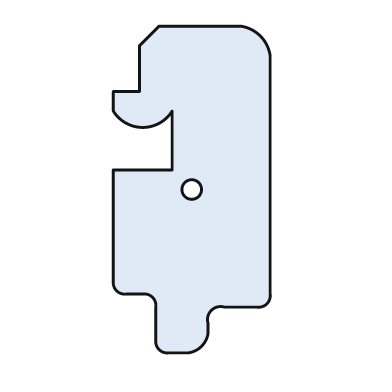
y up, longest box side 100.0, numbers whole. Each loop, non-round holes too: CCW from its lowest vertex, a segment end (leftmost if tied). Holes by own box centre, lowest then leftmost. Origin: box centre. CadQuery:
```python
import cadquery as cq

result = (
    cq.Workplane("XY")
    .moveTo(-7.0, -50.0)
    .lineTo(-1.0, -50.0)
    .threePointArc((3.0, -48.0), (5.0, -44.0))
    .lineTo(5.0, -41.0)
    .threePointArc((6.0, -37.0), (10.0, -36.0))
    .lineTo(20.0, -36.0)
    .threePointArc((23.0, -35.0), (24.0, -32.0))
    .lineTo(24.0, 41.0)
    .threePointArc((21.0, 47.0), (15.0, 50.0))
    .lineTo(-10.0, 50.0)
    .lineTo(-16.0, 44.0)
    .lineTo(-16.0, 30.0)
    .lineTo(-24.0, 30.0)
    .lineTo(-24.0, 24.0)
    .threePointArc((-15.0, 19.0), (-6.0, 24.0))
    .lineTo(-6.0, 6.0)
    .lineTo(-24.0, 6.0)
    .lineTo(-24.0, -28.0)
    .threePointArc((-23.0, -31.0), (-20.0, -32.0))
    .lineTo(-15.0, -32.0)
    .threePointArc((-12.0, -33.0), (-11.0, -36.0))
    .lineTo(-11.0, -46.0)
    .threePointArc((-10.0, -49.0), (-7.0, -50.0))
    .close()
    .moveTo(0.0, 0.0)
    .circle(3.0)
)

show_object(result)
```